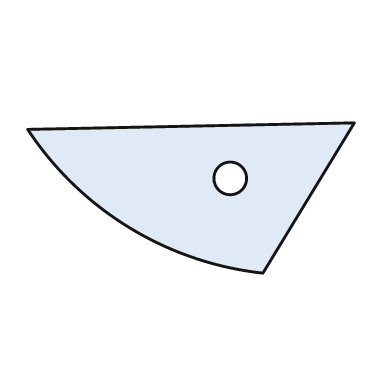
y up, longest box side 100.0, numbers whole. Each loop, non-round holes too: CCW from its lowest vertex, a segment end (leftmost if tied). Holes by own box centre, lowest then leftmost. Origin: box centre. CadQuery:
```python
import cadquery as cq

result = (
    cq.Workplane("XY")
    .moveTo(22.0, -23.0)
    .lineTo(50.0, 23.0)
    .lineTo(-50.0, 21.0)
    .threePointArc((-19.0, -9.0), (22.0, -23.0))
    .close()
    .moveTo(12.0, 6.0)
    .circle(5.0)
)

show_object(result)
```